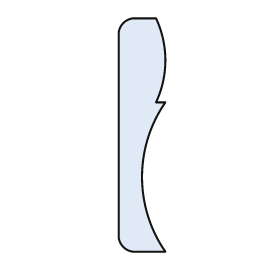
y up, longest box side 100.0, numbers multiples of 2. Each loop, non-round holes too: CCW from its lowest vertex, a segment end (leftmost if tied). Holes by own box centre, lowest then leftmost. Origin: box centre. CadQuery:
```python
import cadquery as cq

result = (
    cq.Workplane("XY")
    .moveTo(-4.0, -50.0)
    .lineTo(10.0, -50.0)
    .threePointArc((0.0, -18.0), (10.0, 14.0))
    .lineTo(6.0, 14.0)
    .threePointArc((10.0, 32.0), (6.0, 50.0))
    .lineTo(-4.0, 50.0)
    .threePointArc((-8.0, 48.0), (-10.0, 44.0))
    .lineTo(-10.0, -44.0)
    .threePointArc((-8.0, -48.0), (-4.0, -50.0))
    .close()
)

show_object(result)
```